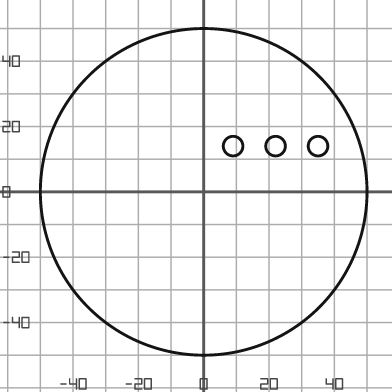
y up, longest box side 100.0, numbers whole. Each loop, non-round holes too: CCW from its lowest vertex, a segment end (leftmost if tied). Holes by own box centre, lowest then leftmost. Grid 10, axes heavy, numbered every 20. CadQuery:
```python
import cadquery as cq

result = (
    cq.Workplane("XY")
    .moveTo(0.0, 0.0)
    .circle(50.0)
    .moveTo(9.0, 14.0)
    .circle(3.0)
    .moveTo(22.0, 14.0)
    .circle(3.0)
    .moveTo(35.0, 14.0)
    .circle(3.0)
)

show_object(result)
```